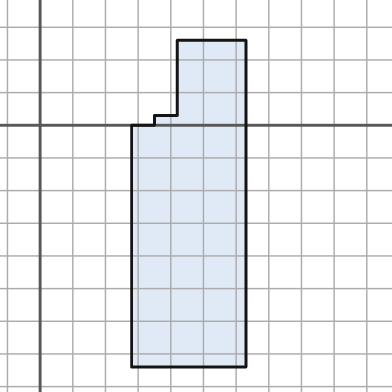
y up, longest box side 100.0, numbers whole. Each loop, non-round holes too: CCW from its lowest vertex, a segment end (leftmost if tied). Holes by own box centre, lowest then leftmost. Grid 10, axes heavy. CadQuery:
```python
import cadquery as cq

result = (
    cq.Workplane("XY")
    .moveTo(28.0, -74.0)
    .lineTo(63.0, -74.0)
    .lineTo(63.0, 26.0)
    .lineTo(42.0, 26.0)
    .lineTo(42.0, 3.0)
    .lineTo(35.0, 3.0)
    .lineTo(35.0, 0.0)
    .lineTo(28.0, 0.0)
    .close()
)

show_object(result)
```